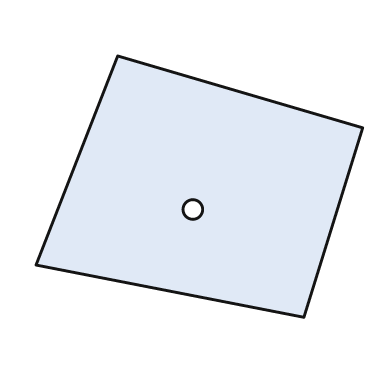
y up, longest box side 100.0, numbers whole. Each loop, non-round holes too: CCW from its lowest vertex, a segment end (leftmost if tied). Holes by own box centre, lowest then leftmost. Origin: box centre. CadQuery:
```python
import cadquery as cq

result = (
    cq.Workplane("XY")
    .moveTo(32.0, -40.0)
    .lineTo(50.0, 18.0)
    .lineTo(-25.0, 40.0)
    .lineTo(-50.0, -24.0)
    .close()
    .moveTo(-2.0, -7.0)
    .circle(3.0)
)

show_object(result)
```